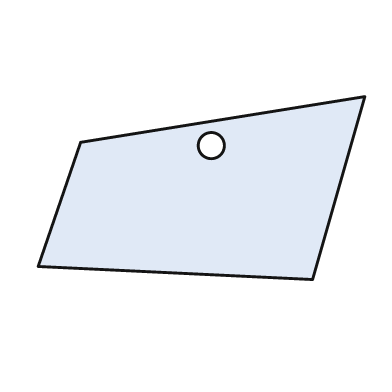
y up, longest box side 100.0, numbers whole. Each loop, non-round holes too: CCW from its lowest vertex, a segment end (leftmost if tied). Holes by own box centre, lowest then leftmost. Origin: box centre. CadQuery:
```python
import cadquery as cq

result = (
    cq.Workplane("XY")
    .moveTo(34.0, -28.0)
    .lineTo(50.0, 28.0)
    .lineTo(-37.0, 14.0)
    .lineTo(-50.0, -24.0)
    .close()
    .moveTo(3.0, 13.0)
    .circle(4.0)
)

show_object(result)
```